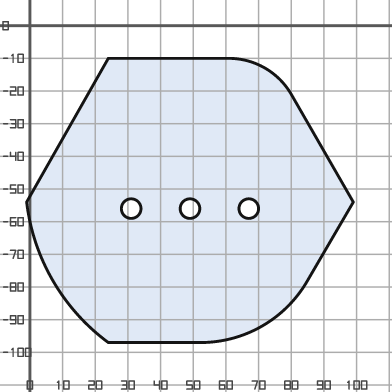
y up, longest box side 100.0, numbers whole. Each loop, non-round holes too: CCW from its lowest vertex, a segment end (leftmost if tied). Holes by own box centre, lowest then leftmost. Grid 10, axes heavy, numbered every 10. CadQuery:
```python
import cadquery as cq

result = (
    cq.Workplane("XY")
    .moveTo(24.0, -97.0)
    .lineTo(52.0, -97.0)
    .threePointArc((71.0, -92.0), (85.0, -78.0))
    .lineTo(99.0, -54.0)
    .lineTo(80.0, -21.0)
    .threePointArc((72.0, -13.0), (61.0, -10.0))
    .lineTo(24.0, -10.0)
    .lineTo(-1.0, -54.0)
    .threePointArc((7.0, -78.0), (24.0, -97.0))
    .close()
    .moveTo(31.0, -56.0)
    .circle(3.0)
    .moveTo(49.0, -56.0)
    .circle(3.0)
    .moveTo(67.0, -56.0)
    .circle(3.0)
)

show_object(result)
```